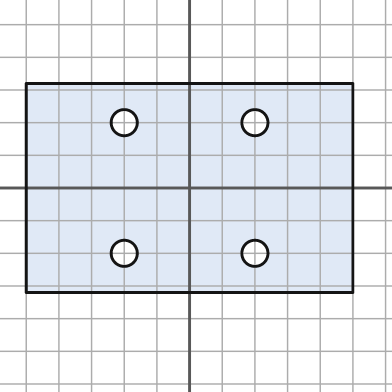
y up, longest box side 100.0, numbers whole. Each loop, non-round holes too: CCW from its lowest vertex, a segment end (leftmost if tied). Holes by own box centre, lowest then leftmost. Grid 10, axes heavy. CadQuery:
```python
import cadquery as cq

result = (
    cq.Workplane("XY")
    .moveTo(-50.0, -32.0)
    .lineTo(50.0, -32.0)
    .lineTo(50.0, 32.0)
    .lineTo(-50.0, 32.0)
    .close()
    .moveTo(-20.0, -20.0)
    .circle(4.0)
    .moveTo(20.0, -20.0)
    .circle(4.0)
    .moveTo(-20.0, 20.0)
    .circle(4.0)
    .moveTo(20.0, 20.0)
    .circle(4.0)
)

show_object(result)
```